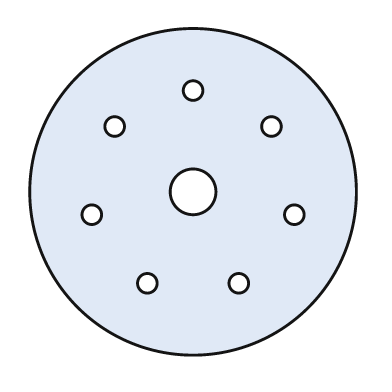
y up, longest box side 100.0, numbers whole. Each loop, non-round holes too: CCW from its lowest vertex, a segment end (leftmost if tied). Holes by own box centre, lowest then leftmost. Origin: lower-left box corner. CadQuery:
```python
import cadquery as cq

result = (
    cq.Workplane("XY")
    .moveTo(50.0, 50.0)
    .circle(50.0)
    .moveTo(36.0, 22.0)
    .circle(3.0)
    .moveTo(64.0, 22.0)
    .circle(3.0)
    .moveTo(19.0, 43.0)
    .circle(3.0)
    .moveTo(81.0, 43.0)
    .circle(3.0)
    .moveTo(50.0, 50.0)
    .circle(7.0)
    .moveTo(26.0, 70.0)
    .circle(3.0)
    .moveTo(74.0, 70.0)
    .circle(3.0)
    .moveTo(50.0, 81.0)
    .circle(3.0)
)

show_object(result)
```